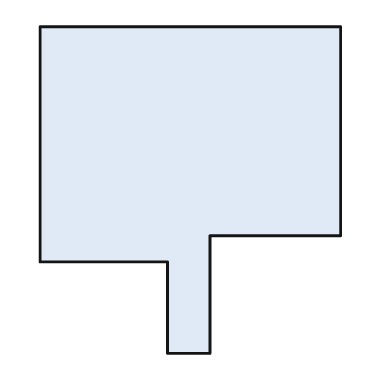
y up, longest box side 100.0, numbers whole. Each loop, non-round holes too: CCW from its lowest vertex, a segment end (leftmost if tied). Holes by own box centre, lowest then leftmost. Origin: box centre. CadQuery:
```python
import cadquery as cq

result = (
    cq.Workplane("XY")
    .moveTo(-7.0, -50.0)
    .lineTo(6.0, -50.0)
    .lineTo(6.0, -14.0)
    .lineTo(46.0, -14.0)
    .lineTo(46.0, 50.0)
    .lineTo(-46.0, 50.0)
    .lineTo(-46.0, -22.0)
    .lineTo(-7.0, -22.0)
    .close()
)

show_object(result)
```